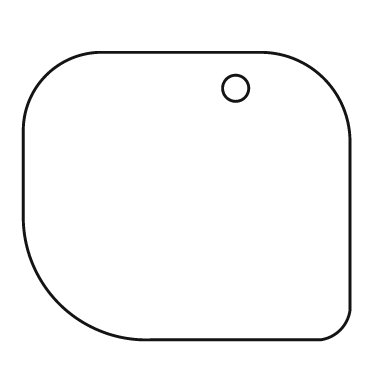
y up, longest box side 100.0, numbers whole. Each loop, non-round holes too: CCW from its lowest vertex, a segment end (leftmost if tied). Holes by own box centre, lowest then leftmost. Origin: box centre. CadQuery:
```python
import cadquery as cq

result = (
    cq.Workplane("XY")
    .moveTo(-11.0, -44.0)
    .lineTo(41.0, -44.0)
    .threePointArc((47.0, -41.0), (50.0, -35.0))
    .lineTo(50.0, 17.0)
    .threePointArc((42.0, 36.0), (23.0, 44.0))
    .lineTo(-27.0, 44.0)
    .threePointArc((-43.0, 37.0), (-50.0, 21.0))
    .lineTo(-50.0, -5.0)
    .threePointArc((-39.0, -33.0), (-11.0, -44.0))
    .close()
    .moveTo(15.0, 33.0)
    .circle(4.0)
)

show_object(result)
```